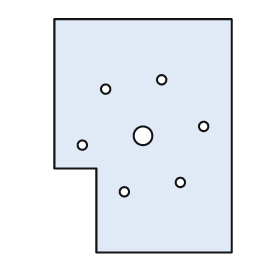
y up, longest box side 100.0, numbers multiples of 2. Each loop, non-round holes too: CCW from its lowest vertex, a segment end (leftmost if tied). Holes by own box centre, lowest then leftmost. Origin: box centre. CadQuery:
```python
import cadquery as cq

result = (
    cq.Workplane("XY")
    .moveTo(-20.0, -50.0)
    .lineTo(38.0, -50.0)
    .lineTo(38.0, 50.0)
    .lineTo(-38.0, 50.0)
    .lineTo(-38.0, -14.0)
    .lineTo(-20.0, -14.0)
    .close()
    .moveTo(-8.0, -24.0)
    .circle(2.0)
    .moveTo(16.0, -20.0)
    .circle(2.0)
    .moveTo(-26.0, -4.0)
    .circle(2.0)
    .moveTo(0.0, 0.0)
    .circle(4.0)
    .moveTo(26.0, 4.0)
    .circle(2.0)
    .moveTo(-16.0, 20.0)
    .circle(2.0)
    .moveTo(8.0, 24.0)
    .circle(2.0)
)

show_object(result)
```